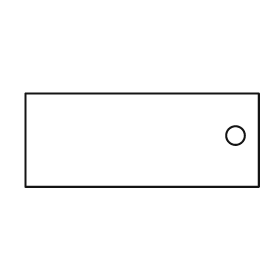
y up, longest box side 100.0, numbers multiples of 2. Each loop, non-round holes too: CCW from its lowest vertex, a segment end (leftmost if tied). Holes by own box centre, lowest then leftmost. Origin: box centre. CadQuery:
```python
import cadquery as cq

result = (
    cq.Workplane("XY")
    .moveTo(-50.0, -20.0)
    .lineTo(50.0, -20.0)
    .lineTo(50.0, 20.0)
    .lineTo(-50.0, 20.0)
    .close()
    .moveTo(40.0, 2.0)
    .circle(4.0)
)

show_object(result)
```